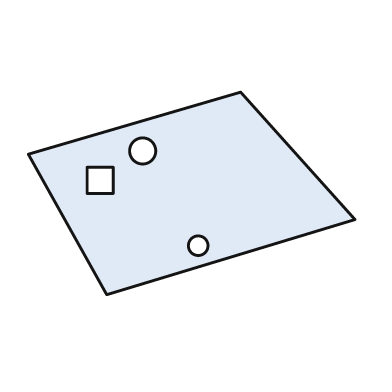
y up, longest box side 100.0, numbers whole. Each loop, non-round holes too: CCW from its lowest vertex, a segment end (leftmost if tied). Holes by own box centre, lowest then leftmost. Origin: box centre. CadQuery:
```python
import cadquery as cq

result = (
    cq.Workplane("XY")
    .moveTo(-26.0, -31.0)
    .lineTo(50.0, -8.0)
    .lineTo(15.0, 31.0)
    .lineTo(-50.0, 12.0)
    .close()
    .moveTo(2.0, -16.0)
    .circle(3.0)
    .moveTo(-32.0, 0.0)
    .lineTo(-24.0, 0.0)
    .lineTo(-24.0, 8.0)
    .lineTo(-32.0, 8.0)
    .close()
    .moveTo(-15.0, 13.0)
    .circle(4.0)
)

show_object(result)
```